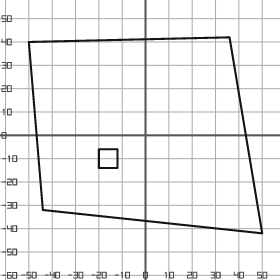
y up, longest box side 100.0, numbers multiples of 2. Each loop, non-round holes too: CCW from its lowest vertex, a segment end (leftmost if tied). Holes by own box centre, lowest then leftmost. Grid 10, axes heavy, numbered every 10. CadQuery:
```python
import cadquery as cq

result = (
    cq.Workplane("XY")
    .moveTo(50.0, -42.0)
    .lineTo(36.0, 42.0)
    .lineTo(-50.0, 40.0)
    .lineTo(-44.0, -32.0)
    .close()
    .moveTo(-20.0, -14.0)
    .lineTo(-12.0, -14.0)
    .lineTo(-12.0, -6.0)
    .lineTo(-20.0, -6.0)
    .close()
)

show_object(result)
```